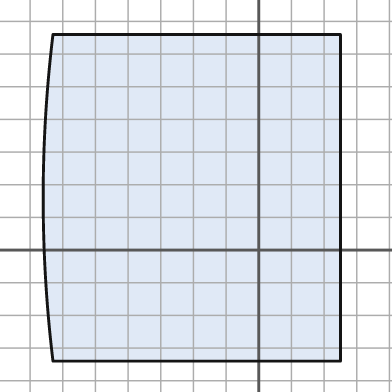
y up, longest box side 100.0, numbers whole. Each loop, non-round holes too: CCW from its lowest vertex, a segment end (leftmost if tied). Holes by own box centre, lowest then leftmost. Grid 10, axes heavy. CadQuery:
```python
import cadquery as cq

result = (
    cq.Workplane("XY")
    .moveTo(-63.0, -34.0)
    .lineTo(25.0, -34.0)
    .lineTo(25.0, 66.0)
    .lineTo(-63.0, 66.0)
    .threePointArc((-66.0, 16.0), (-63.0, -34.0))
    .close()
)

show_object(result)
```